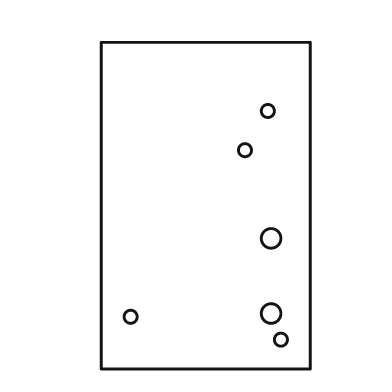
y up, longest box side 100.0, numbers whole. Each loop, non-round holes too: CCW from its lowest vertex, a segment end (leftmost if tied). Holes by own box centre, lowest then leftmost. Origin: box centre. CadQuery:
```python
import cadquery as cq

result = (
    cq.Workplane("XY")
    .moveTo(-32.0, -50.0)
    .lineTo(32.0, -50.0)
    .lineTo(32.0, 50.0)
    .lineTo(-32.0, 50.0)
    .close()
    .moveTo(23.0, -41.0)
    .circle(2.0)
    .moveTo(-23.0, -34.0)
    .circle(2.0)
    .moveTo(20.0, -33.0)
    .circle(3.0)
    .moveTo(20.0, -10.0)
    .circle(3.0)
    .moveTo(12.0, 17.0)
    .circle(2.0)
    .moveTo(19.0, 29.0)
    .circle(2.0)
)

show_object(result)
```